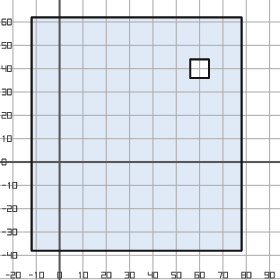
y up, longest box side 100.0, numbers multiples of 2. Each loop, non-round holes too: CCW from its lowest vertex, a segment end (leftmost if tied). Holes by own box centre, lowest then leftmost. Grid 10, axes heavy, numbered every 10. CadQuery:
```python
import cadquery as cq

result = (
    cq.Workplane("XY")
    .moveTo(-12.0, -38.0)
    .lineTo(78.0, -38.0)
    .lineTo(78.0, 62.0)
    .lineTo(-12.0, 62.0)
    .close()
    .moveTo(56.0, 36.0)
    .lineTo(64.0, 36.0)
    .lineTo(64.0, 44.0)
    .lineTo(56.0, 44.0)
    .close()
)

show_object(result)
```